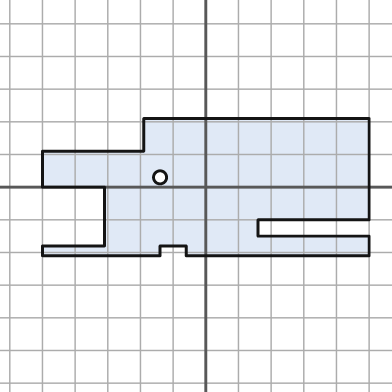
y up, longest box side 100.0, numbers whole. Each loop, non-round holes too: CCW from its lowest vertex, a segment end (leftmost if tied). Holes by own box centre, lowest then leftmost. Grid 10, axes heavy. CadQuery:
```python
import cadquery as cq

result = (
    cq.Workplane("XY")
    .moveTo(-50.0, -21.0)
    .lineTo(-14.0, -21.0)
    .lineTo(-14.0, -18.0)
    .lineTo(-6.0, -18.0)
    .lineTo(-6.0, -21.0)
    .lineTo(50.0, -21.0)
    .lineTo(50.0, -15.0)
    .lineTo(16.0, -15.0)
    .lineTo(16.0, -10.0)
    .lineTo(50.0, -10.0)
    .lineTo(50.0, 21.0)
    .lineTo(-19.0, 21.0)
    .lineTo(-19.0, 11.0)
    .lineTo(-50.0, 11.0)
    .lineTo(-50.0, 0.0)
    .lineTo(-31.0, 0.0)
    .lineTo(-31.0, -18.0)
    .lineTo(-50.0, -18.0)
    .close()
    .moveTo(-14.0, 3.0)
    .circle(2.0)
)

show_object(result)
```